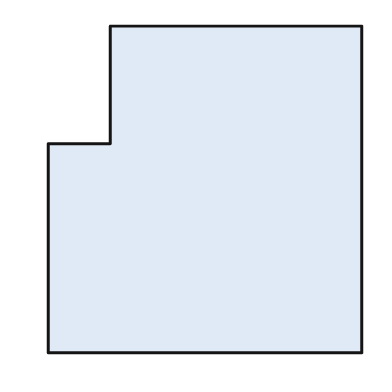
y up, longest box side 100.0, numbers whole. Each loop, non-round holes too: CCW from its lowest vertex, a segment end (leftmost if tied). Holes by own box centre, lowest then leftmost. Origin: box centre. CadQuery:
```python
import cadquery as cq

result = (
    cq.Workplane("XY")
    .moveTo(-48.0, -50.0)
    .lineTo(48.0, -50.0)
    .lineTo(48.0, 50.0)
    .lineTo(-29.0, 50.0)
    .lineTo(-29.0, 14.0)
    .lineTo(-48.0, 14.0)
    .close()
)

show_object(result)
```